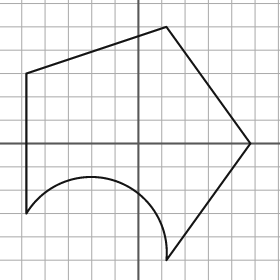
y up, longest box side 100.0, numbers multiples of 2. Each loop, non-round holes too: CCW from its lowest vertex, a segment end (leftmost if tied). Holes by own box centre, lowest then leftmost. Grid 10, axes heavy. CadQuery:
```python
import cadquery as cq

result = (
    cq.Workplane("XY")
    .moveTo(12.0, -50.0)
    .lineTo(48.0, 0.0)
    .lineTo(12.0, 50.0)
    .lineTo(-48.0, 30.0)
    .lineTo(-48.0, -30.0)
    .threePointArc((-10.0, -16.0), (12.0, -50.0))
    .close()
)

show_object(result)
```